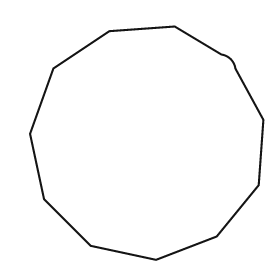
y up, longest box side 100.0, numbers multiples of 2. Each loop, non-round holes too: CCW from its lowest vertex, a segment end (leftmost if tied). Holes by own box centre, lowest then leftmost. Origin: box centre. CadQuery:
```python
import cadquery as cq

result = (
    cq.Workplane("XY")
    .moveTo(4.0, -50.0)
    .lineTo(30.0, -40.0)
    .lineTo(48.0, -18.0)
    .lineTo(50.0, 10.0)
    .lineTo(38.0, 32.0)
    .threePointArc((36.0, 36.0), (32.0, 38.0))
    .lineTo(12.0, 50.0)
    .lineTo(-16.0, 48.0)
    .lineTo(-40.0, 32.0)
    .lineTo(-50.0, 4.0)
    .lineTo(-44.0, -24.0)
    .lineTo(-24.0, -44.0)
    .close()
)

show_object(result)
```